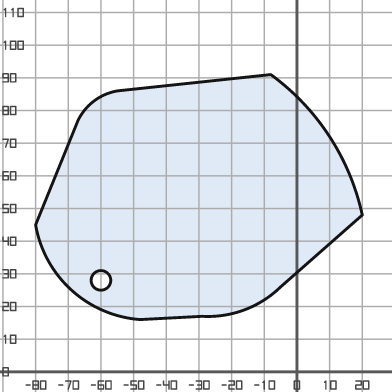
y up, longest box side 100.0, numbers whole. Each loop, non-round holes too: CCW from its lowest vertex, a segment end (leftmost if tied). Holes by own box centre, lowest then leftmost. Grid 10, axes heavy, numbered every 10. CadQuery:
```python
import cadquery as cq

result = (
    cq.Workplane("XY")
    .moveTo(-48.0, 16.0)
    .lineTo(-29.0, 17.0)
    .threePointArc((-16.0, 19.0), (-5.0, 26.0))
    .lineTo(20.0, 48.0)
    .threePointArc((10.0, 72.0), (-8.0, 91.0))
    .lineTo(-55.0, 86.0)
    .threePointArc((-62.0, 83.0), (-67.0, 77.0))
    .lineTo(-80.0, 45.0)
    .threePointArc((-69.0, 25.0), (-48.0, 16.0))
    .close()
    .moveTo(-60.0, 28.0)
    .circle(3.0)
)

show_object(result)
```